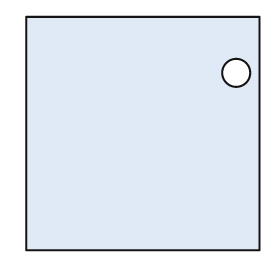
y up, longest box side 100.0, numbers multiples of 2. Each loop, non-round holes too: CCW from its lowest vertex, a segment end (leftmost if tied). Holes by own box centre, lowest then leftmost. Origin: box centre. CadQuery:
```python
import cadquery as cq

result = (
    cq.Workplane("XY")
    .moveTo(-50.0, -50.0)
    .lineTo(50.0, -50.0)
    .lineTo(50.0, 50.0)
    .lineTo(-50.0, 50.0)
    .close()
    .moveTo(40.0, 26.0)
    .circle(6.0)
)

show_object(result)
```